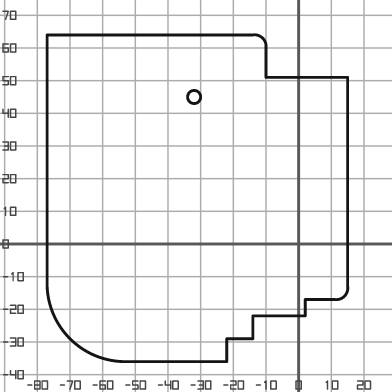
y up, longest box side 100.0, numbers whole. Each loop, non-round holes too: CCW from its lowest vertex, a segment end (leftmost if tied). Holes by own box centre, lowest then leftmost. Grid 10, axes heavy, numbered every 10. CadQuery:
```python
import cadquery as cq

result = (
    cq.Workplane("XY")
    .moveTo(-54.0, -36.0)
    .lineTo(-22.0, -36.0)
    .lineTo(-22.0, -29.0)
    .lineTo(-14.0, -29.0)
    .lineTo(-14.0, -22.0)
    .lineTo(2.0, -22.0)
    .lineTo(2.0, -17.0)
    .lineTo(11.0, -17.0)
    .threePointArc((14.0, -16.0), (15.0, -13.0))
    .lineTo(15.0, 51.0)
    .lineTo(-10.0, 51.0)
    .lineTo(-10.0, 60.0)
    .threePointArc((-11.0, 63.0), (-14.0, 64.0))
    .lineTo(-77.0, 64.0)
    .lineTo(-77.0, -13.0)
    .threePointArc((-70.0, -29.0), (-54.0, -36.0))
    .close()
    .moveTo(-32.0, 45.0)
    .circle(2.0)
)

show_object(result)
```